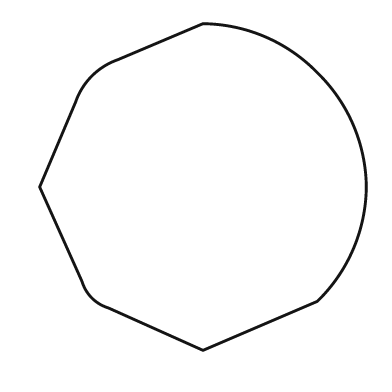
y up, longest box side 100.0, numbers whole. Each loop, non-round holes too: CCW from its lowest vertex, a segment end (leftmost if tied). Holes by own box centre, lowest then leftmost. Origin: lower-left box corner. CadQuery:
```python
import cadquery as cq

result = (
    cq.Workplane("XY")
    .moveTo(50.0, 0.0)
    .lineTo(85.0, 15.0)
    .threePointArc((96.0, 31.0), (100.0, 50.0))
    .threePointArc((96.0, 69.0), (85.0, 85.0))
    .threePointArc((69.0, 96.0), (50.0, 100.0))
    .lineTo(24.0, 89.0)
    .threePointArc((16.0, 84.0), (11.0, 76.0))
    .lineTo(0.0, 50.0)
    .lineTo(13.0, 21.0)
    .threePointArc((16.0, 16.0), (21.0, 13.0))
    .close()
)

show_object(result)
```